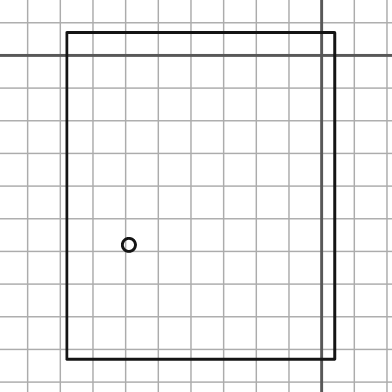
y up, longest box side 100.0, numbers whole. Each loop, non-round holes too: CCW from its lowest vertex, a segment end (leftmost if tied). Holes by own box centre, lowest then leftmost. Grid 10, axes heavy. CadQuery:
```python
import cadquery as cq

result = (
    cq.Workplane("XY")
    .moveTo(-78.0, -93.0)
    .lineTo(4.0, -93.0)
    .lineTo(4.0, 7.0)
    .lineTo(-78.0, 7.0)
    .close()
    .moveTo(-59.0, -58.0)
    .circle(2.0)
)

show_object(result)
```